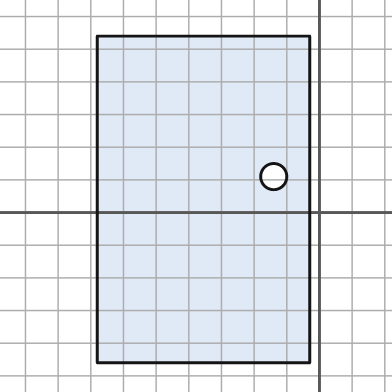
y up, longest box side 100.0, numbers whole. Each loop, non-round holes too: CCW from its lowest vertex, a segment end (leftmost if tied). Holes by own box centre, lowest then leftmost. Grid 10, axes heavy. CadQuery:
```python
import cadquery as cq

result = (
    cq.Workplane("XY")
    .moveTo(-68.0, -46.0)
    .lineTo(-3.0, -46.0)
    .lineTo(-3.0, 54.0)
    .lineTo(-68.0, 54.0)
    .close()
    .moveTo(-14.0, 11.0)
    .circle(4.0)
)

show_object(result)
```